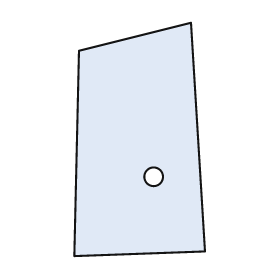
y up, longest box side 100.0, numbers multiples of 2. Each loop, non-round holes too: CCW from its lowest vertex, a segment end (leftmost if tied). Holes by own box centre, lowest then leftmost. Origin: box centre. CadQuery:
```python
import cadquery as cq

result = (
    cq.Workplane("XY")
    .moveTo(-28.0, -50.0)
    .lineTo(28.0, -48.0)
    .lineTo(22.0, 50.0)
    .lineTo(-26.0, 38.0)
    .close()
    .moveTo(6.0, -16.0)
    .circle(4.0)
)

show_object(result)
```